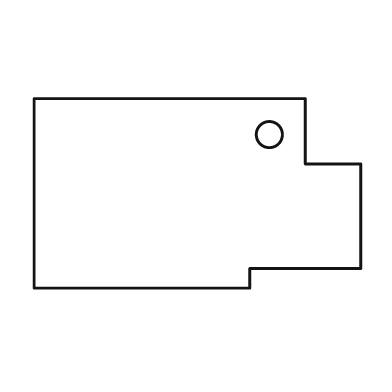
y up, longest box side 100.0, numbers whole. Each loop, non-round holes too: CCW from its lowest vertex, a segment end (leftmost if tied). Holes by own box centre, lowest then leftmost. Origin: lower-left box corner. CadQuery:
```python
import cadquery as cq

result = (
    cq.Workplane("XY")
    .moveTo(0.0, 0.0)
    .lineTo(66.0, 0.0)
    .lineTo(66.0, 6.0)
    .lineTo(100.0, 6.0)
    .lineTo(100.0, 38.0)
    .lineTo(83.0, 38.0)
    .lineTo(83.0, 58.0)
    .lineTo(0.0, 58.0)
    .close()
    .moveTo(72.0, 47.0)
    .circle(4.0)
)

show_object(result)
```